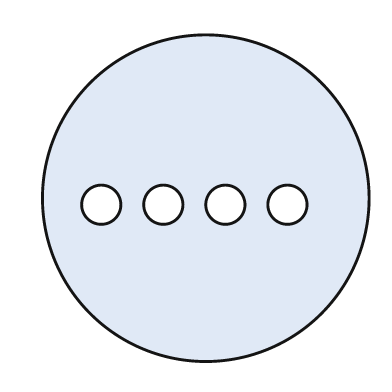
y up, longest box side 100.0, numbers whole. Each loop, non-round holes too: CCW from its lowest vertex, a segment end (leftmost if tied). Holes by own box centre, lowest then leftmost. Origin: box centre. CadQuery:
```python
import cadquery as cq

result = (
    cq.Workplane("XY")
    .moveTo(0.0, 0.0)
    .circle(50.0)
    .moveTo(-32.0, -2.0)
    .circle(6.0)
    .moveTo(-13.0, -2.0)
    .circle(6.0)
    .moveTo(6.0, -2.0)
    .circle(6.0)
    .moveTo(25.0, -2.0)
    .circle(6.0)
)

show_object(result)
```